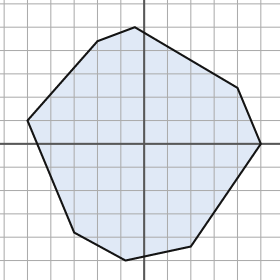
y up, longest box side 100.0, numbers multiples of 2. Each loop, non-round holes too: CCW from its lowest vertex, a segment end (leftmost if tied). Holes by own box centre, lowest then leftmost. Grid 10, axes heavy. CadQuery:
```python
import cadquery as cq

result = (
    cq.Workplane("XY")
    .moveTo(-8.0, -50.0)
    .lineTo(20.0, -44.0)
    .lineTo(50.0, 0.0)
    .lineTo(40.0, 24.0)
    .lineTo(-4.0, 50.0)
    .lineTo(-20.0, 44.0)
    .lineTo(-50.0, 10.0)
    .lineTo(-30.0, -38.0)
    .close()
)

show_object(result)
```